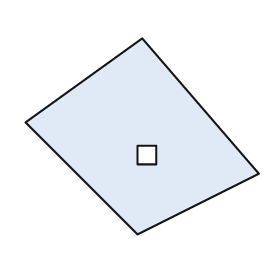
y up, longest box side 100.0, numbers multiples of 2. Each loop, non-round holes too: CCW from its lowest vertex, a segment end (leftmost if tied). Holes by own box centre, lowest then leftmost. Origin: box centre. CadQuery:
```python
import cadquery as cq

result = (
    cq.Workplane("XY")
    .moveTo(-2.0, -42.0)
    .lineTo(50.0, -16.0)
    .lineTo(0.0, 42.0)
    .lineTo(-50.0, 6.0)
    .close()
    .moveTo(-2.0, -12.0)
    .lineTo(6.0, -12.0)
    .lineTo(6.0, -4.0)
    .lineTo(-2.0, -4.0)
    .close()
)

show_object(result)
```